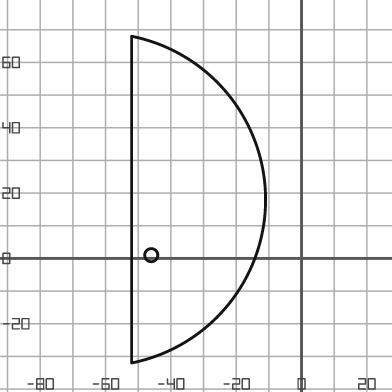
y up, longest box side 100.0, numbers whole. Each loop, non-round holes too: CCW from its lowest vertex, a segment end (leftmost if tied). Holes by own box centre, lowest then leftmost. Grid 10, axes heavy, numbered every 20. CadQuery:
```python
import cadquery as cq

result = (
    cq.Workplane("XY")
    .moveTo(-52.0, -32.0)
    .threePointArc((-11.0, 18.0), (-52.0, 68.0))
    .close()
    .moveTo(-46.0, 1.0)
    .circle(2.0)
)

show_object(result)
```